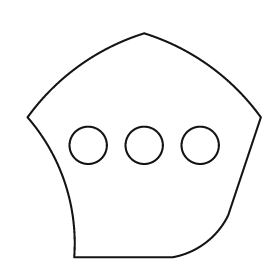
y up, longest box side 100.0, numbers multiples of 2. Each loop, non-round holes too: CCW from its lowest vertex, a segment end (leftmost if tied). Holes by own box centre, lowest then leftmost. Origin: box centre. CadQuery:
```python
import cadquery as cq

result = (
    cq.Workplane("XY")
    .moveTo(-30.0, -48.0)
    .lineTo(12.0, -48.0)
    .threePointArc((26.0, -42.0), (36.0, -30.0))
    .lineTo(50.0, 12.0)
    .threePointArc((28.0, 34.0), (0.0, 48.0))
    .threePointArc((-28.0, 34.0), (-50.0, 12.0))
    .threePointArc((-34.0, -16.0), (-30.0, -48.0))
    .close()
    .moveTo(-24.0, 0.0)
    .circle(8.0)
    .moveTo(0.0, 0.0)
    .circle(8.0)
    .moveTo(24.0, 0.0)
    .circle(8.0)
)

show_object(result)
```